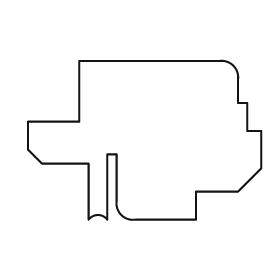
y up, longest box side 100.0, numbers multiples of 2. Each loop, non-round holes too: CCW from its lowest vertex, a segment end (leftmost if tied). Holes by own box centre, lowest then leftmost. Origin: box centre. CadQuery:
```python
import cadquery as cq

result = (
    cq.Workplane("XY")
    .moveTo(-24.0, -34.0)
    .threePointArc((-20.0, -32.0), (-16.0, -34.0))
    .lineTo(-16.0, -6.0)
    .lineTo(-12.0, -6.0)
    .lineTo(-12.0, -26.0)
    .threePointArc((-10.0, -32.0), (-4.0, -34.0))
    .lineTo(22.0, -34.0)
    .lineTo(22.0, -22.0)
    .lineTo(40.0, -22.0)
    .lineTo(50.0, -12.0)
    .lineTo(50.0, 4.0)
    .lineTo(44.0, 4.0)
    .lineTo(44.0, 16.0)
    .lineTo(40.0, 16.0)
    .lineTo(40.0, 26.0)
    .threePointArc((38.0, 32.0), (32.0, 34.0))
    .lineTo(-28.0, 34.0)
    .lineTo(-28.0, 8.0)
    .lineTo(-50.0, 8.0)
    .lineTo(-50.0, -4.0)
    .lineTo(-44.0, -10.0)
    .lineTo(-24.0, -10.0)
    .close()
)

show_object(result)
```